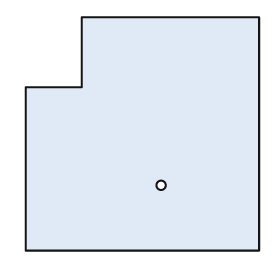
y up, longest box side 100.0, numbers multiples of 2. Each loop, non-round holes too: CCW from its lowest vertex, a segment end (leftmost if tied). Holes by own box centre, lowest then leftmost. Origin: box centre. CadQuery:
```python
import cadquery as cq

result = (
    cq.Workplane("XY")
    .moveTo(-50.0, -50.0)
    .lineTo(50.0, -50.0)
    .lineTo(50.0, 50.0)
    .lineTo(-26.0, 50.0)
    .lineTo(-26.0, 20.0)
    .lineTo(-50.0, 20.0)
    .close()
    .moveTo(8.0, -22.0)
    .circle(2.0)
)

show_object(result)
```